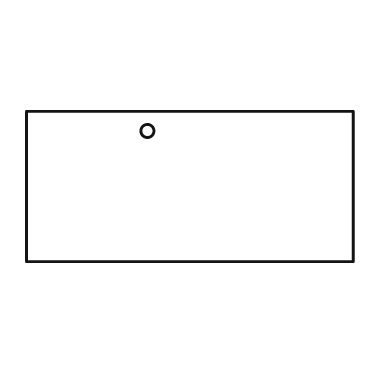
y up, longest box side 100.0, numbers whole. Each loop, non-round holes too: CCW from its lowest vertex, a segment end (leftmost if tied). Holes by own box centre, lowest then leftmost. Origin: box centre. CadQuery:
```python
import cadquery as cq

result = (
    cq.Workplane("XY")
    .moveTo(-50.0, -23.0)
    .lineTo(50.0, -23.0)
    .lineTo(50.0, 23.0)
    .lineTo(-50.0, 23.0)
    .close()
    .moveTo(-13.0, 17.0)
    .circle(2.0)
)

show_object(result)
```